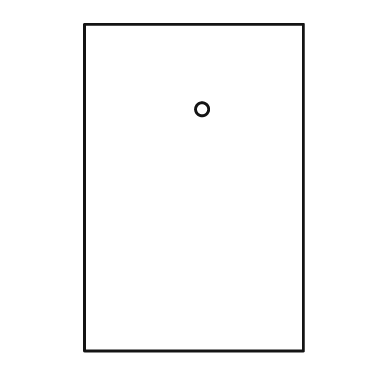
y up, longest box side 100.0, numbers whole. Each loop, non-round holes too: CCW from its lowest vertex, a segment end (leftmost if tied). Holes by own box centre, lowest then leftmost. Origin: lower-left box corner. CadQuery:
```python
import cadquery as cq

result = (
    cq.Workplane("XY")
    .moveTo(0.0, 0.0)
    .lineTo(67.0, 0.0)
    .lineTo(67.0, 100.0)
    .lineTo(0.0, 100.0)
    .close()
    .moveTo(36.0, 74.0)
    .circle(2.0)
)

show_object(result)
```